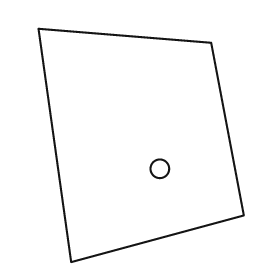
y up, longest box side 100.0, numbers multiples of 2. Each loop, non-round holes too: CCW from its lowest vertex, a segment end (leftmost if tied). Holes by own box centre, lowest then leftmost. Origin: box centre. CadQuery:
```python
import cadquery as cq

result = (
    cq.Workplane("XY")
    .moveTo(-30.0, -50.0)
    .lineTo(44.0, -30.0)
    .lineTo(30.0, 44.0)
    .lineTo(-44.0, 50.0)
    .close()
    .moveTo(8.0, -10.0)
    .circle(4.0)
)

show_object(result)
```